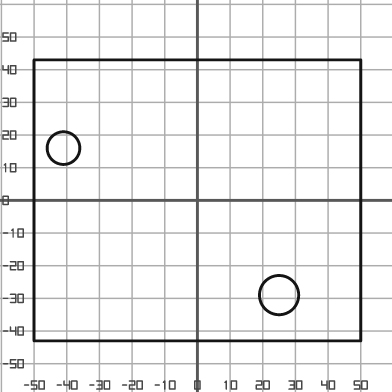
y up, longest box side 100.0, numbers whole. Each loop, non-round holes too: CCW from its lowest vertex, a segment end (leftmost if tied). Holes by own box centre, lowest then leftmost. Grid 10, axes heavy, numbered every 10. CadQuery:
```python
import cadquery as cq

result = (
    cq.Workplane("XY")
    .moveTo(-50.0, -43.0)
    .lineTo(50.0, -43.0)
    .lineTo(50.0, 43.0)
    .lineTo(-50.0, 43.0)
    .close()
    .moveTo(25.0, -29.0)
    .circle(6.0)
    .moveTo(-41.0, 16.0)
    .circle(5.0)
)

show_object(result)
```